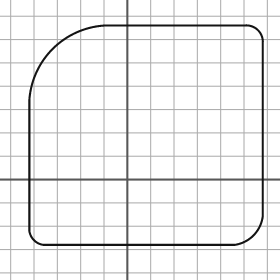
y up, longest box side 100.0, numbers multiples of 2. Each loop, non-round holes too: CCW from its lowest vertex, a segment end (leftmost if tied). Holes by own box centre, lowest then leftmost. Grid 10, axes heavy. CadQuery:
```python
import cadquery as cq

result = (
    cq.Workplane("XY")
    .moveTo(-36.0, -28.0)
    .lineTo(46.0, -28.0)
    .threePointArc((54.0, -24.0), (58.0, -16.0))
    .lineTo(58.0, 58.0)
    .threePointArc((56.0, 64.0), (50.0, 66.0))
    .lineTo(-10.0, 66.0)
    .threePointArc((-32.0, 56.0), (-42.0, 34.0))
    .lineTo(-42.0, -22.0)
    .threePointArc((-40.0, -26.0), (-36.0, -28.0))
    .close()
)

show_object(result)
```